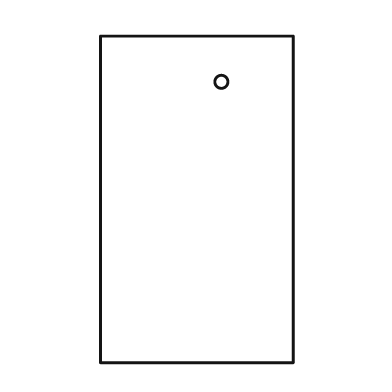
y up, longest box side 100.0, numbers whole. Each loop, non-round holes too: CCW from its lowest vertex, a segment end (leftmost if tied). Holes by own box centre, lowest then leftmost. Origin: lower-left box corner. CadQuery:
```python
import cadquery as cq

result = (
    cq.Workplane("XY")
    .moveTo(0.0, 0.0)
    .lineTo(59.0, 0.0)
    .lineTo(59.0, 100.0)
    .lineTo(0.0, 100.0)
    .close()
    .moveTo(37.0, 86.0)
    .circle(2.0)
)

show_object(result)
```